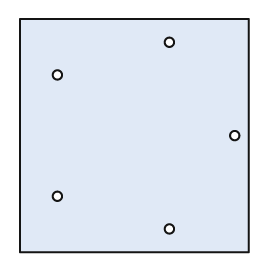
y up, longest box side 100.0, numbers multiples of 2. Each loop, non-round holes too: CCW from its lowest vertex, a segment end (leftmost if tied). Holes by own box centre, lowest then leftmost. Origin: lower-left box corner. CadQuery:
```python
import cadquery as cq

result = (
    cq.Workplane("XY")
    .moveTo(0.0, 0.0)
    .lineTo(98.0, 0.0)
    .lineTo(98.0, 100.0)
    .lineTo(0.0, 100.0)
    .close()
    .moveTo(64.0, 10.0)
    .circle(2.0)
    .moveTo(16.0, 24.0)
    .circle(2.0)
    .moveTo(92.0, 50.0)
    .circle(2.0)
    .moveTo(16.0, 76.0)
    .circle(2.0)
    .moveTo(64.0, 90.0)
    .circle(2.0)
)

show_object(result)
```